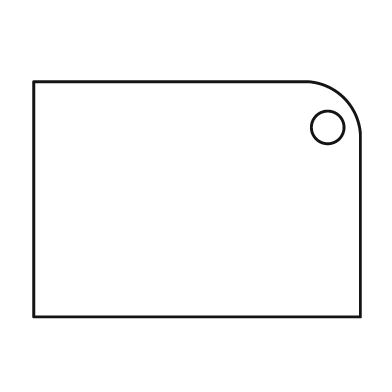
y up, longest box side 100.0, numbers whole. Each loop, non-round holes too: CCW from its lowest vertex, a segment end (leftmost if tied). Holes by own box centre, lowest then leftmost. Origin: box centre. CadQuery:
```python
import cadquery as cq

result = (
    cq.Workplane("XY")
    .moveTo(-50.0, -36.0)
    .lineTo(50.0, -36.0)
    .lineTo(50.0, 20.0)
    .threePointArc((45.0, 31.0), (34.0, 36.0))
    .lineTo(-50.0, 36.0)
    .close()
    .moveTo(40.0, 22.0)
    .circle(5.0)
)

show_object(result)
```